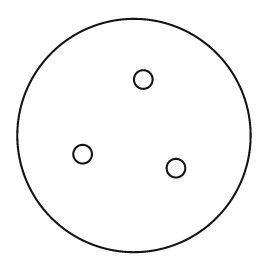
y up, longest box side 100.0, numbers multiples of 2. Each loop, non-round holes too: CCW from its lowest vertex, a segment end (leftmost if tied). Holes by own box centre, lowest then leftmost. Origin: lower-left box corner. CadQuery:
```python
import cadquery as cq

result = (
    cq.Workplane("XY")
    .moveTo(50.0, 50.0)
    .circle(50.0)
    .moveTo(68.0, 36.0)
    .circle(4.0)
    .moveTo(28.0, 42.0)
    .circle(4.0)
    .moveTo(54.0, 74.0)
    .circle(4.0)
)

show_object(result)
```